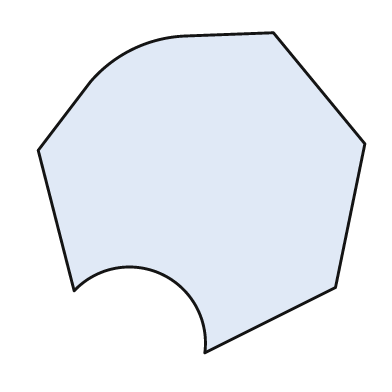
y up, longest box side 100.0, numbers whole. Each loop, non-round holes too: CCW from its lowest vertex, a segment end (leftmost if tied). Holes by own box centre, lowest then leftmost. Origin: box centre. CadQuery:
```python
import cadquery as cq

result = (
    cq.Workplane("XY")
    .moveTo(1.0, -49.0)
    .lineTo(41.0, -29.0)
    .lineTo(50.0, 15.0)
    .lineTo(22.0, 49.0)
    .lineTo(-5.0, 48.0)
    .threePointArc((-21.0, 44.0), (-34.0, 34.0))
    .lineTo(-50.0, 13.0)
    .lineTo(-39.0, -30.0)
    .threePointArc((-12.0, -25.0), (1.0, -49.0))
    .close()
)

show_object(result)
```